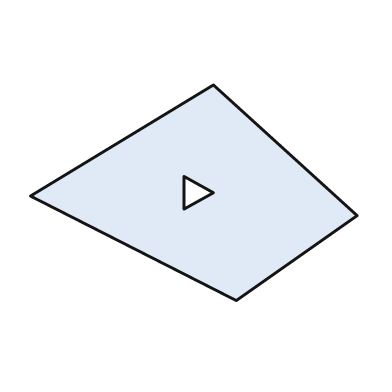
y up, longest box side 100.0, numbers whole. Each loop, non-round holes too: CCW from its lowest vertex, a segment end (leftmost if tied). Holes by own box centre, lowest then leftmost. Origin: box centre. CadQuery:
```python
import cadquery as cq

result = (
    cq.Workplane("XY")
    .moveTo(13.0, -33.0)
    .lineTo(50.0, -7.0)
    .lineTo(6.0, 33.0)
    .lineTo(-50.0, -1.0)
    .close()
    .moveTo(-3.0, -5.0)
    .lineTo(6.0, 0.0)
    .lineTo(-3.0, 5.0)
    .close()
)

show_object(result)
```